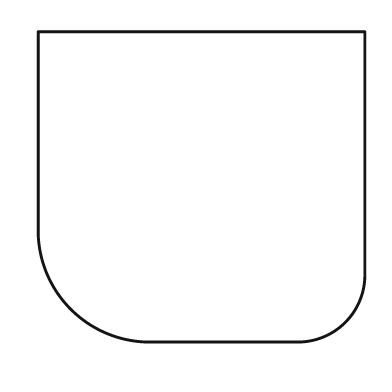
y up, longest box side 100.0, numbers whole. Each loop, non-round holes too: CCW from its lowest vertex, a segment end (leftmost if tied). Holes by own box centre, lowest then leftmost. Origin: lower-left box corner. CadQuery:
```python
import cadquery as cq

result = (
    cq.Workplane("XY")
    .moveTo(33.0, 0.0)
    .lineTo(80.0, 0.0)
    .threePointArc((94.0, 6.0), (100.0, 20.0))
    .lineTo(100.0, 95.0)
    .lineTo(0.0, 95.0)
    .lineTo(0.0, 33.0)
    .threePointArc((10.0, 10.0), (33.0, 0.0))
    .close()
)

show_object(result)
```